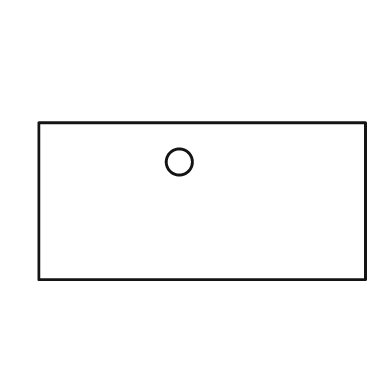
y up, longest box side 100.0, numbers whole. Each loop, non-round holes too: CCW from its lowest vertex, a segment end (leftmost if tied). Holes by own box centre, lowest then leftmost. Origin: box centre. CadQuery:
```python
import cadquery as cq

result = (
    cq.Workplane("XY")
    .moveTo(-50.0, -24.0)
    .lineTo(50.0, -24.0)
    .lineTo(50.0, 24.0)
    .lineTo(-50.0, 24.0)
    .close()
    .moveTo(-7.0, 12.0)
    .circle(4.0)
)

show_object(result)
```